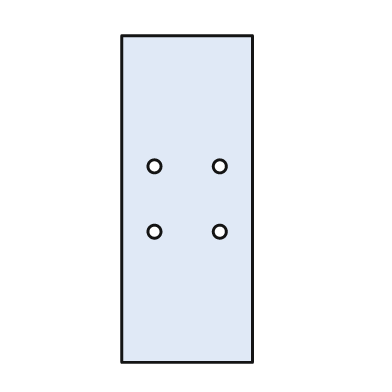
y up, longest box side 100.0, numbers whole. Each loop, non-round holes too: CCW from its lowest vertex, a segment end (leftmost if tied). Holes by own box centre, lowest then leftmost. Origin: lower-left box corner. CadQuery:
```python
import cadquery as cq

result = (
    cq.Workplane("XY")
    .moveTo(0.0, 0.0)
    .lineTo(40.0, 0.0)
    .lineTo(40.0, 100.0)
    .lineTo(0.0, 100.0)
    .close()
    .moveTo(10.0, 40.0)
    .circle(2.0)
    .moveTo(30.0, 40.0)
    .circle(2.0)
    .moveTo(10.0, 60.0)
    .circle(2.0)
    .moveTo(30.0, 60.0)
    .circle(2.0)
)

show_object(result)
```